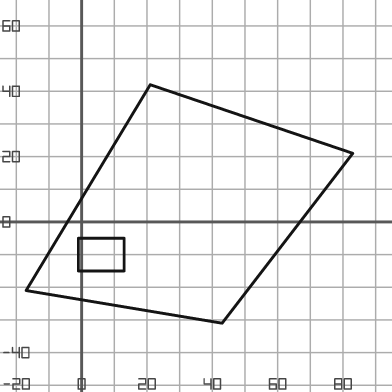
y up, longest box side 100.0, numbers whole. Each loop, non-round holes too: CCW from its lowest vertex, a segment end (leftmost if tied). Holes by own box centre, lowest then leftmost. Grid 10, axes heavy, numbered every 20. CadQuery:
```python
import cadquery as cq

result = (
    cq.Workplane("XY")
    .moveTo(43.0, -31.0)
    .lineTo(83.0, 21.0)
    .lineTo(21.0, 42.0)
    .lineTo(-17.0, -21.0)
    .close()
    .moveTo(-1.0, -15.0)
    .lineTo(13.0, -15.0)
    .lineTo(13.0, -5.0)
    .lineTo(-1.0, -5.0)
    .close()
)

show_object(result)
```